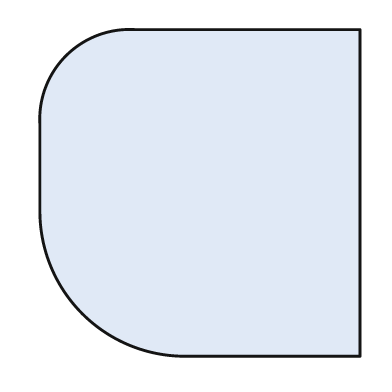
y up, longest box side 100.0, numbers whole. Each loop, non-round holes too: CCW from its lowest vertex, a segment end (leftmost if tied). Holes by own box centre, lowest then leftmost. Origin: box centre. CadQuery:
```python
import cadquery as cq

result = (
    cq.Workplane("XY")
    .moveTo(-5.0, -50.0)
    .lineTo(49.0, -50.0)
    .lineTo(49.0, 50.0)
    .lineTo(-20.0, 50.0)
    .threePointArc((-41.0, 42.0), (-49.0, 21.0))
    .lineTo(-49.0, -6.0)
    .threePointArc((-36.0, -37.0), (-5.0, -50.0))
    .close()
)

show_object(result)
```